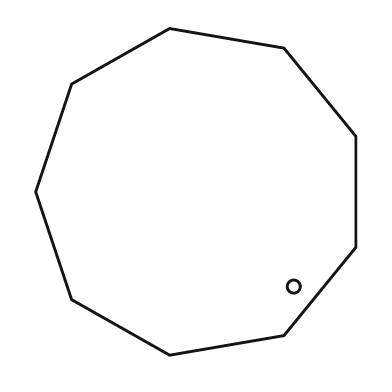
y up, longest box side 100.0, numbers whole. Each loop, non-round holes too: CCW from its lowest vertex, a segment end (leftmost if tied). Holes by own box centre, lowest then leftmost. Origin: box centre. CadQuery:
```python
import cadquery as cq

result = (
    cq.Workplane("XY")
    .moveTo(-8.0, -50.0)
    .lineTo(27.0, -44.0)
    .lineTo(49.0, -17.0)
    .lineTo(49.0, 17.0)
    .lineTo(27.0, 44.0)
    .lineTo(-8.0, 50.0)
    .lineTo(-38.0, 33.0)
    .lineTo(-49.0, 0.0)
    .lineTo(-38.0, -33.0)
    .close()
    .moveTo(30.0, -29.0)
    .circle(2.0)
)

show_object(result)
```